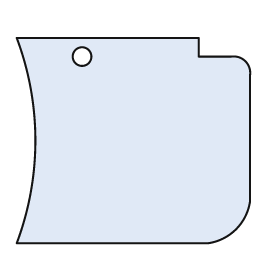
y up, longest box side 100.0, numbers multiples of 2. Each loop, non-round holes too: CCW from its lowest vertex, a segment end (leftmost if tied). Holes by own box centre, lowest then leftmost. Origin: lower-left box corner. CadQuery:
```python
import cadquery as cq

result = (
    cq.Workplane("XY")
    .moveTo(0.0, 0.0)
    .lineTo(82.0, 0.0)
    .threePointArc((94.0, 6.0), (100.0, 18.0))
    .lineTo(100.0, 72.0)
    .threePointArc((98.0, 78.0), (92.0, 80.0))
    .lineTo(78.0, 80.0)
    .lineTo(78.0, 88.0)
    .lineTo(0.0, 88.0)
    .threePointArc((8.0, 44.0), (0.0, 0.0))
    .close()
    .moveTo(28.0, 80.0)
    .circle(4.0)
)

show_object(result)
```